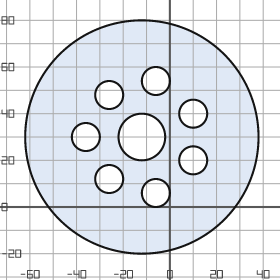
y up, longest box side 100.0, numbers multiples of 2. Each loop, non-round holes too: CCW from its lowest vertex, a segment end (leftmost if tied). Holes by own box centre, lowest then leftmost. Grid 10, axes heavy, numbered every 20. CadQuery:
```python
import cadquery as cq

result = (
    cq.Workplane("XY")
    .moveTo(-12.0, 30.0)
    .circle(50.0)
    .moveTo(-6.0, 6.0)
    .circle(6.0)
    .moveTo(-26.0, 12.0)
    .circle(6.0)
    .moveTo(10.0, 20.0)
    .circle(6.0)
    .moveTo(-36.0, 30.0)
    .circle(6.0)
    .moveTo(-12.0, 30.0)
    .circle(10.0)
    .moveTo(10.0, 40.0)
    .circle(6.0)
    .moveTo(-26.0, 48.0)
    .circle(6.0)
    .moveTo(-6.0, 54.0)
    .circle(6.0)
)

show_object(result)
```